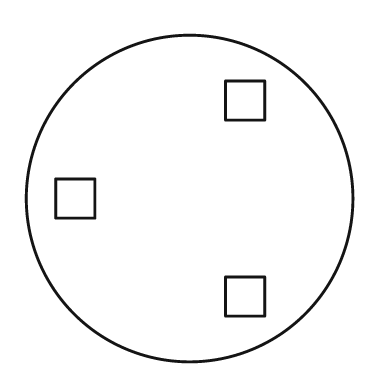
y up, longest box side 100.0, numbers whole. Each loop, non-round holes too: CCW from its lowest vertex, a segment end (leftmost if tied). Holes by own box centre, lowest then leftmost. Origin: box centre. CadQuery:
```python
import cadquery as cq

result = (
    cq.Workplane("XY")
    .moveTo(0.0, 0.0)
    .circle(50.0)
    .moveTo(11.0, -36.0)
    .lineTo(23.0, -36.0)
    .lineTo(23.0, -24.0)
    .lineTo(11.0, -24.0)
    .close()
    .moveTo(-41.0, -6.0)
    .lineTo(-29.0, -6.0)
    .lineTo(-29.0, 6.0)
    .lineTo(-41.0, 6.0)
    .close()
    .moveTo(11.0, 24.0)
    .lineTo(23.0, 24.0)
    .lineTo(23.0, 36.0)
    .lineTo(11.0, 36.0)
    .close()
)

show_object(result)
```